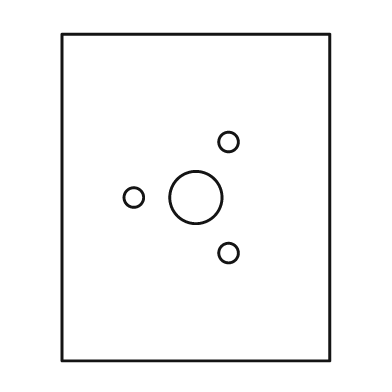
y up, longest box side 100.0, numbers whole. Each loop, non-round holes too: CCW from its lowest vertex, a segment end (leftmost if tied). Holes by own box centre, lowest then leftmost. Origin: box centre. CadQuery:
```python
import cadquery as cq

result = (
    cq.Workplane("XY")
    .moveTo(-41.0, -50.0)
    .lineTo(41.0, -50.0)
    .lineTo(41.0, 50.0)
    .lineTo(-41.0, 50.0)
    .close()
    .moveTo(10.0, -17.0)
    .circle(3.0)
    .moveTo(-19.0, 0.0)
    .circle(3.0)
    .moveTo(0.0, 0.0)
    .circle(8.0)
    .moveTo(10.0, 17.0)
    .circle(3.0)
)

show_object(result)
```